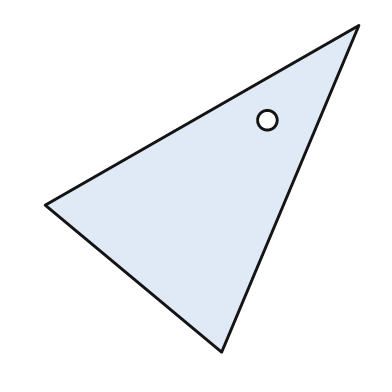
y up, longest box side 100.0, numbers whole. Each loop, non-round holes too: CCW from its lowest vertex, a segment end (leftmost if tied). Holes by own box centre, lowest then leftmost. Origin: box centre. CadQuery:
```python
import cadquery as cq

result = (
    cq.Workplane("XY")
    .moveTo(6.0, -50.0)
    .lineTo(48.0, 50.0)
    .lineTo(-48.0, -5.0)
    .close()
    .moveTo(20.0, 21.0)
    .circle(3.0)
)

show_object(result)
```